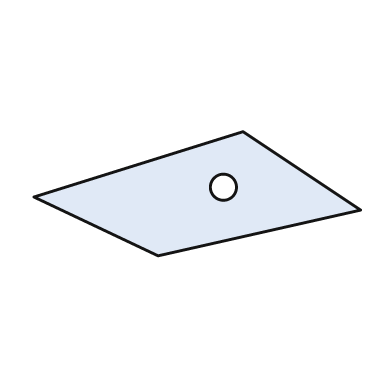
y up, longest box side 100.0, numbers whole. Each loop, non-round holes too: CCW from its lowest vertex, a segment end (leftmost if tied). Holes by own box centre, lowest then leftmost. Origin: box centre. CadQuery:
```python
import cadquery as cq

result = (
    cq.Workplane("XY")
    .moveTo(-12.0, -19.0)
    .lineTo(50.0, -5.0)
    .lineTo(14.0, 19.0)
    .lineTo(-50.0, -1.0)
    .close()
    .moveTo(8.0, 2.0)
    .circle(4.0)
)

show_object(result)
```